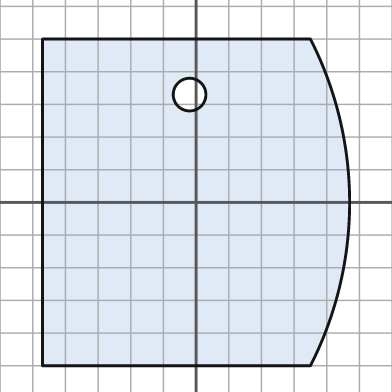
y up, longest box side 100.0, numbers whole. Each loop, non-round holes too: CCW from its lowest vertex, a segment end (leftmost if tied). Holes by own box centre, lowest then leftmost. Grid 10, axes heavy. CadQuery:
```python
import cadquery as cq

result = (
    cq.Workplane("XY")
    .moveTo(-47.0, -50.0)
    .lineTo(35.0, -50.0)
    .threePointArc((47.0, 0.0), (35.0, 50.0))
    .lineTo(-47.0, 50.0)
    .close()
    .moveTo(-2.0, 33.0)
    .circle(5.0)
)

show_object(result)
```